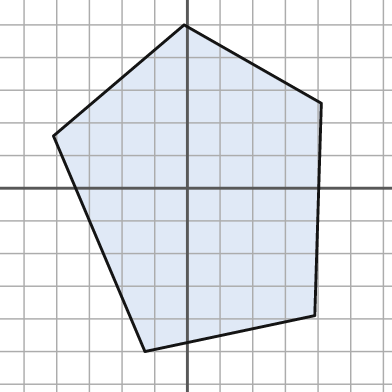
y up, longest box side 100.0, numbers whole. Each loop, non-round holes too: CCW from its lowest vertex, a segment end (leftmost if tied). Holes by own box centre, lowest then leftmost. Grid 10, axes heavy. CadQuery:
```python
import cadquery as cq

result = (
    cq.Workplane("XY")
    .moveTo(-13.0, -50.0)
    .lineTo(39.0, -39.0)
    .lineTo(41.0, 26.0)
    .lineTo(-1.0, 50.0)
    .lineTo(-41.0, 16.0)
    .close()
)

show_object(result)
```